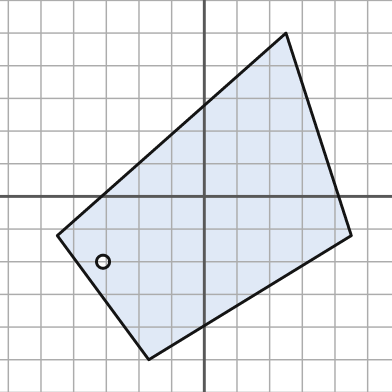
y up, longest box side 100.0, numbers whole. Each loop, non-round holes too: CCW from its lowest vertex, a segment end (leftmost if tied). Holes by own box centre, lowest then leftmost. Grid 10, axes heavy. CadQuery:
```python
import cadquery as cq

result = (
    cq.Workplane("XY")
    .moveTo(-17.0, -50.0)
    .lineTo(45.0, -12.0)
    .lineTo(25.0, 50.0)
    .lineTo(-45.0, -12.0)
    .close()
    .moveTo(-31.0, -20.0)
    .circle(2.0)
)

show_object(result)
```